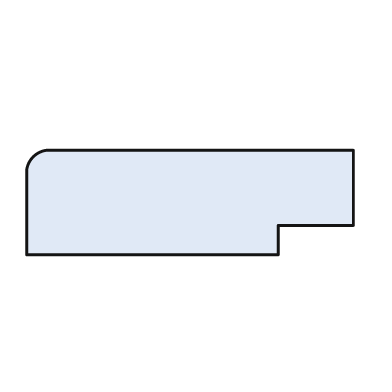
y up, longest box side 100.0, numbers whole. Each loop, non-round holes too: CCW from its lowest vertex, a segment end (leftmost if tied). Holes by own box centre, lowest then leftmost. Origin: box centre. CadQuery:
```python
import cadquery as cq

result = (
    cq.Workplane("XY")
    .moveTo(-50.0, -16.0)
    .lineTo(27.0, -16.0)
    .lineTo(27.0, -7.0)
    .lineTo(50.0, -7.0)
    .lineTo(50.0, 16.0)
    .lineTo(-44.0, 16.0)
    .threePointArc((-48.0, 14.0), (-50.0, 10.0))
    .close()
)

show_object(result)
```